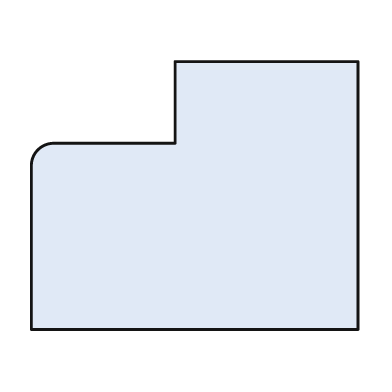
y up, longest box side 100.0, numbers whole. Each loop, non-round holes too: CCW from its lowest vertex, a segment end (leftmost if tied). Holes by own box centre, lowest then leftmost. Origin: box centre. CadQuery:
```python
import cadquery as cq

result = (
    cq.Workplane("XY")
    .moveTo(-50.0, -41.0)
    .lineTo(50.0, -41.0)
    .lineTo(50.0, 41.0)
    .lineTo(-6.0, 41.0)
    .lineTo(-6.0, 16.0)
    .lineTo(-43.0, 16.0)
    .threePointArc((-48.0, 14.0), (-50.0, 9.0))
    .close()
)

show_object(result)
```